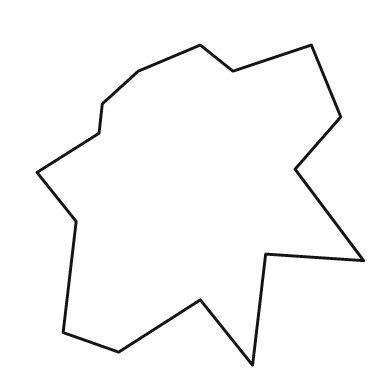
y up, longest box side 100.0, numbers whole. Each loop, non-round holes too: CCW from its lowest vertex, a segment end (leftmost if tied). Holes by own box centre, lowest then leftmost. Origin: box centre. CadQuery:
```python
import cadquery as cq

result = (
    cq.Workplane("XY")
    .moveTo(16.0, -49.0)
    .lineTo(20.0, -15.0)
    .lineTo(50.0, -17.0)
    .lineTo(29.0, 11.0)
    .lineTo(43.0, 27.0)
    .lineTo(34.0, 49.0)
    .lineTo(10.0, 41.0)
    .lineTo(0.0, 49.0)
    .lineTo(-19.0, 41.0)
    .lineTo(-30.0, 31.0)
    .lineTo(-31.0, 22.0)
    .lineTo(-50.0, 10.0)
    .lineTo(-38.0, -5.0)
    .lineTo(-42.0, -39.0)
    .lineTo(-25.0, -45.0)
    .lineTo(0.0, -29.0)
    .close()
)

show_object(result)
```